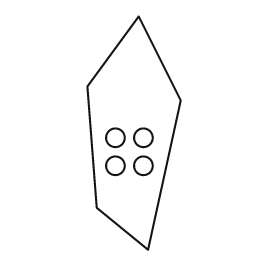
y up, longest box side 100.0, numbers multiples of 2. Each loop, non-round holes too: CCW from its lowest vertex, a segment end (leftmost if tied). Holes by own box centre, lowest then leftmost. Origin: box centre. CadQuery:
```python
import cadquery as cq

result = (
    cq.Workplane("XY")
    .moveTo(6.0, -50.0)
    .lineTo(20.0, 14.0)
    .lineTo(2.0, 50.0)
    .lineTo(-20.0, 20.0)
    .lineTo(-16.0, -32.0)
    .close()
    .moveTo(-8.0, -14.0)
    .circle(4.0)
    .moveTo(4.0, -14.0)
    .circle(4.0)
    .moveTo(-8.0, -2.0)
    .circle(4.0)
    .moveTo(4.0, -2.0)
    .circle(4.0)
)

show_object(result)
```